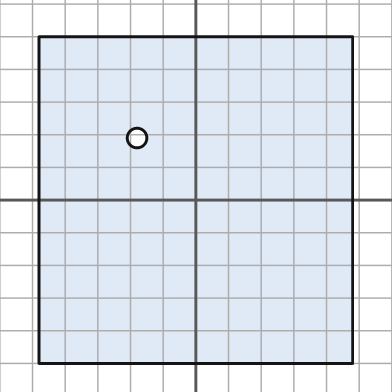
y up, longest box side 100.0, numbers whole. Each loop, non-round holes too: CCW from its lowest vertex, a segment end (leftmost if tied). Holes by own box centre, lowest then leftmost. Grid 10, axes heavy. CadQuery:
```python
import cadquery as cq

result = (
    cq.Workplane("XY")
    .moveTo(-48.0, -50.0)
    .lineTo(48.0, -50.0)
    .lineTo(48.0, 50.0)
    .lineTo(-48.0, 50.0)
    .close()
    .moveTo(-18.0, 19.0)
    .circle(3.0)
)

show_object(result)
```